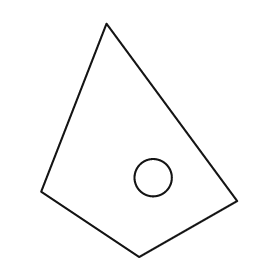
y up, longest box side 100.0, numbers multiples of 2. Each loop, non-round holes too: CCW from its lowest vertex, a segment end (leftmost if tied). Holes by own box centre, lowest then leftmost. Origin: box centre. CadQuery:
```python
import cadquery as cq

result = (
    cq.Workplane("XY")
    .moveTo(0.0, -50.0)
    .lineTo(42.0, -26.0)
    .lineTo(-14.0, 50.0)
    .lineTo(-42.0, -22.0)
    .close()
    .moveTo(6.0, -16.0)
    .circle(8.0)
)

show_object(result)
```